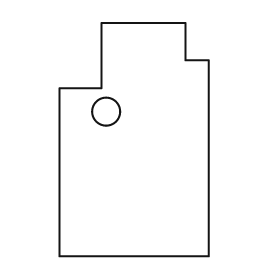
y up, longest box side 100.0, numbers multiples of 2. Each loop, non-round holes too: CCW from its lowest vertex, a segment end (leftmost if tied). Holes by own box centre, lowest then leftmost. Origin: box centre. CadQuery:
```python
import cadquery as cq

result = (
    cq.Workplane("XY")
    .moveTo(-32.0, -50.0)
    .lineTo(32.0, -50.0)
    .lineTo(32.0, 34.0)
    .lineTo(22.0, 34.0)
    .lineTo(22.0, 50.0)
    .lineTo(-14.0, 50.0)
    .lineTo(-14.0, 22.0)
    .lineTo(-32.0, 22.0)
    .close()
    .moveTo(-12.0, 12.0)
    .circle(6.0)
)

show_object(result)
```